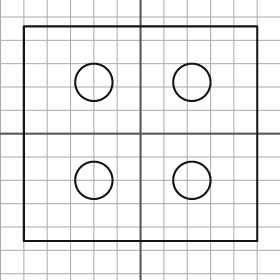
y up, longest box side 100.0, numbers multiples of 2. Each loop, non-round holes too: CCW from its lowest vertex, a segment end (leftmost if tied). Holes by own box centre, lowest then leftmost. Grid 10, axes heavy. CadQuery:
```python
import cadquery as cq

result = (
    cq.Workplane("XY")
    .moveTo(-50.0, -46.0)
    .lineTo(50.0, -46.0)
    .lineTo(50.0, 46.0)
    .lineTo(-50.0, 46.0)
    .close()
    .moveTo(-20.0, -20.0)
    .circle(8.0)
    .moveTo(22.0, -20.0)
    .circle(8.0)
    .moveTo(-20.0, 22.0)
    .circle(8.0)
    .moveTo(22.0, 22.0)
    .circle(8.0)
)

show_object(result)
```